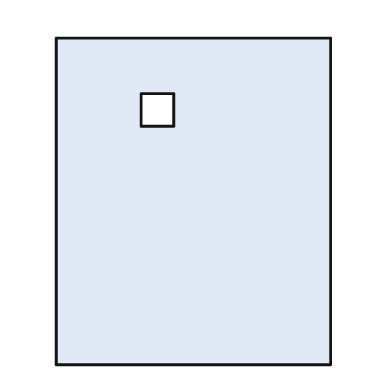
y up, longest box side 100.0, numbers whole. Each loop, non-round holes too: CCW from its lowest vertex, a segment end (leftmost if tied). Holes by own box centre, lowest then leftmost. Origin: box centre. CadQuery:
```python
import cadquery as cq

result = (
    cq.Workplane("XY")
    .moveTo(-42.0, -50.0)
    .lineTo(42.0, -50.0)
    .lineTo(42.0, 50.0)
    .lineTo(-42.0, 50.0)
    .close()
    .moveTo(-16.0, 23.0)
    .lineTo(-6.0, 23.0)
    .lineTo(-6.0, 33.0)
    .lineTo(-16.0, 33.0)
    .close()
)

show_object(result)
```